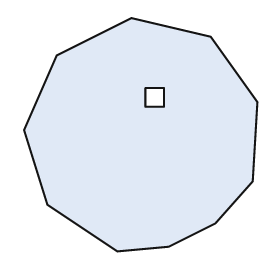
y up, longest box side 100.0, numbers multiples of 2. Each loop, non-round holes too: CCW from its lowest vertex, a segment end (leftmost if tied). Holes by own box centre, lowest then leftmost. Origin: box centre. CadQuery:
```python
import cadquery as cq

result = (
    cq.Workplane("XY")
    .moveTo(-10.0, -50.0)
    .lineTo(12.0, -48.0)
    .lineTo(32.0, -38.0)
    .lineTo(48.0, -20.0)
    .lineTo(50.0, 14.0)
    .lineTo(30.0, 42.0)
    .lineTo(-4.0, 50.0)
    .lineTo(-36.0, 34.0)
    .lineTo(-50.0, 2.0)
    .lineTo(-40.0, -30.0)
    .close()
    .moveTo(2.0, 12.0)
    .lineTo(10.0, 12.0)
    .lineTo(10.0, 20.0)
    .lineTo(2.0, 20.0)
    .close()
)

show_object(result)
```